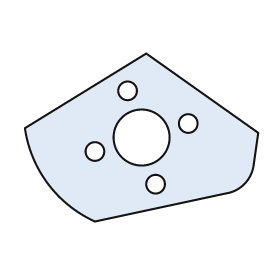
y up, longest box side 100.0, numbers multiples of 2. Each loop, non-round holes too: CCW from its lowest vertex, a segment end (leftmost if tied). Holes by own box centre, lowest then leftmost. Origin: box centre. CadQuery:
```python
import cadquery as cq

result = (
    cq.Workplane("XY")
    .moveTo(-20.0, -36.0)
    .lineTo(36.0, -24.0)
    .threePointArc((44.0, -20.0), (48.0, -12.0))
    .lineTo(50.0, 2.0)
    .lineTo(2.0, 36.0)
    .lineTo(-50.0, 4.0)
    .threePointArc((-40.0, -20.0), (-20.0, -36.0))
    .close()
    .moveTo(6.0, -20.0)
    .circle(4.0)
    .moveTo(-20.0, -6.0)
    .circle(4.0)
    .moveTo(0.0, 0.0)
    .circle(12.0)
    .moveTo(20.0, 6.0)
    .circle(4.0)
    .moveTo(-6.0, 20.0)
    .circle(4.0)
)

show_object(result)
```